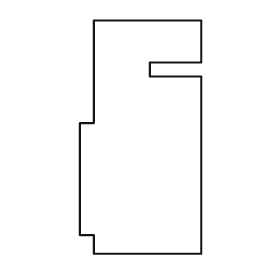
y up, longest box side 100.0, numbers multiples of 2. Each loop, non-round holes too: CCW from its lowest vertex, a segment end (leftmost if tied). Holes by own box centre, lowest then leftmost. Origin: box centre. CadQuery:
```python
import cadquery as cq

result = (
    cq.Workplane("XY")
    .moveTo(-20.0, -50.0)
    .lineTo(26.0, -50.0)
    .lineTo(26.0, 26.0)
    .lineTo(4.0, 26.0)
    .lineTo(4.0, 32.0)
    .lineTo(26.0, 32.0)
    .lineTo(26.0, 50.0)
    .lineTo(-20.0, 50.0)
    .lineTo(-20.0, 6.0)
    .lineTo(-26.0, 6.0)
    .lineTo(-26.0, -42.0)
    .lineTo(-20.0, -42.0)
    .close()
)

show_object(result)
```